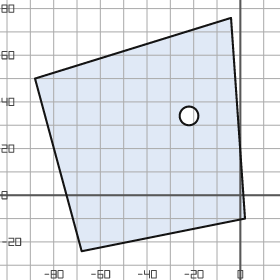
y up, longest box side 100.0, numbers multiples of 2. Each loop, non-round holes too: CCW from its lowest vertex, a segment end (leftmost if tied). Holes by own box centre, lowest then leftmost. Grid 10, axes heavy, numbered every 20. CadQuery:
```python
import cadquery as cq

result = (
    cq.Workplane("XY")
    .moveTo(-68.0, -24.0)
    .lineTo(2.0, -10.0)
    .lineTo(-4.0, 76.0)
    .lineTo(-88.0, 50.0)
    .close()
    .moveTo(-22.0, 34.0)
    .circle(4.0)
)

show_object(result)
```